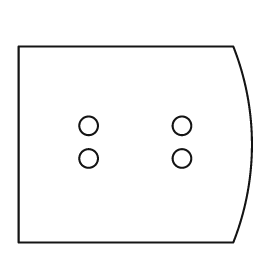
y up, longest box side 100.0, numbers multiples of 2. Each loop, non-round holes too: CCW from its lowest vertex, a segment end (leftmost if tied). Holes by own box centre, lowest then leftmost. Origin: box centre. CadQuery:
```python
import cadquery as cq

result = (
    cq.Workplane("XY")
    .moveTo(-50.0, -42.0)
    .lineTo(42.0, -42.0)
    .threePointArc((50.0, 0.0), (42.0, 42.0))
    .lineTo(-50.0, 42.0)
    .close()
    .moveTo(-20.0, -6.0)
    .circle(4.0)
    .moveTo(20.0, -6.0)
    .circle(4.0)
    .moveTo(-20.0, 8.0)
    .circle(4.0)
    .moveTo(20.0, 8.0)
    .circle(4.0)
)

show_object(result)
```